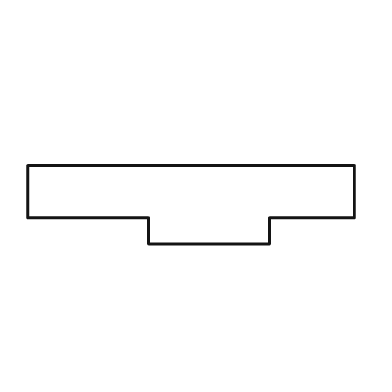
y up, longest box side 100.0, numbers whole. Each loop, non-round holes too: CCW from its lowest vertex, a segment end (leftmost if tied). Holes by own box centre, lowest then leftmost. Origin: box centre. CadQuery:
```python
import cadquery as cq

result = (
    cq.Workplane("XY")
    .moveTo(-13.0, -12.0)
    .lineTo(24.0, -12.0)
    .lineTo(24.0, -4.0)
    .lineTo(50.0, -4.0)
    .lineTo(50.0, 12.0)
    .lineTo(-50.0, 12.0)
    .lineTo(-50.0, -4.0)
    .lineTo(-13.0, -4.0)
    .close()
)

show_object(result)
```